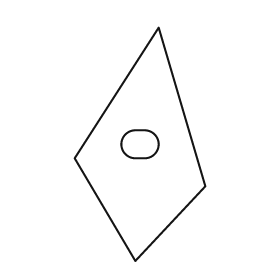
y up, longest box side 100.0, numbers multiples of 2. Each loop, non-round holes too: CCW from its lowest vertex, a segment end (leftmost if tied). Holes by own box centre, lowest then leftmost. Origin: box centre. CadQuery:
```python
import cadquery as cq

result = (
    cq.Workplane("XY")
    .moveTo(-2.0, -50.0)
    .lineTo(28.0, -18.0)
    .lineTo(8.0, 50.0)
    .lineTo(-28.0, -6.0)
    .close()
    .moveTo(-2.0, -6.0)
    .lineTo(2.0, -6.0)
    .threePointArc((8.0, 0.0), (2.0, 6.0))
    .lineTo(-2.0, 6.0)
    .threePointArc((-8.0, 0.0), (-2.0, -6.0))
    .close()
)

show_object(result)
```